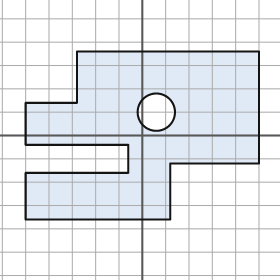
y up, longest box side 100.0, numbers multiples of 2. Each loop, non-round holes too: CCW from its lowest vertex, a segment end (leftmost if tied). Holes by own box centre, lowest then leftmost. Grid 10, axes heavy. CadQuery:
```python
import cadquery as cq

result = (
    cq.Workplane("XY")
    .moveTo(-50.0, -36.0)
    .lineTo(12.0, -36.0)
    .lineTo(12.0, -12.0)
    .lineTo(50.0, -12.0)
    .lineTo(50.0, 36.0)
    .lineTo(-28.0, 36.0)
    .lineTo(-28.0, 14.0)
    .lineTo(-50.0, 14.0)
    .lineTo(-50.0, -4.0)
    .lineTo(-6.0, -4.0)
    .lineTo(-6.0, -16.0)
    .lineTo(-50.0, -16.0)
    .close()
    .moveTo(6.0, 10.0)
    .circle(8.0)
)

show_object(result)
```